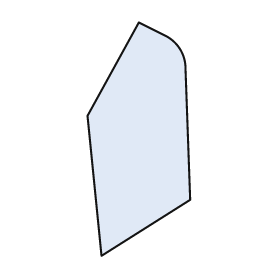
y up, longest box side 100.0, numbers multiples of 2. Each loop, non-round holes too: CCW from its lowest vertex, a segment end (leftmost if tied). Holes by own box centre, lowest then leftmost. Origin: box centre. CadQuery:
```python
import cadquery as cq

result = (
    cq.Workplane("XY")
    .moveTo(-16.0, -50.0)
    .lineTo(22.0, -26.0)
    .lineTo(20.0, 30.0)
    .threePointArc((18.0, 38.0), (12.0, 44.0))
    .lineTo(0.0, 50.0)
    .lineTo(-22.0, 10.0)
    .close()
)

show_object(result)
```